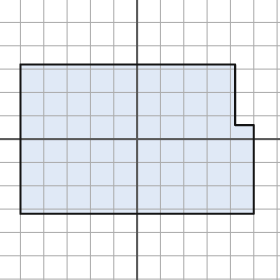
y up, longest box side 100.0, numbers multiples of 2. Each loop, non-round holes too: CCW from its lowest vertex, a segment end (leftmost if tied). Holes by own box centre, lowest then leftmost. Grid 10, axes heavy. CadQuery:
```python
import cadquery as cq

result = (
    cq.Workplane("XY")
    .moveTo(-50.0, -32.0)
    .lineTo(50.0, -32.0)
    .lineTo(50.0, 6.0)
    .lineTo(42.0, 6.0)
    .lineTo(42.0, 32.0)
    .lineTo(-50.0, 32.0)
    .close()
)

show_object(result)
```